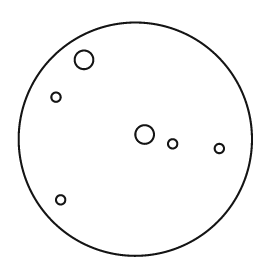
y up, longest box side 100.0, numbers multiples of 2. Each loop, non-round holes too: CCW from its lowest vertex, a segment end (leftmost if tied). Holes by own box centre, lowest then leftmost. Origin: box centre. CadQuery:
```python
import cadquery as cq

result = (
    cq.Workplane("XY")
    .moveTo(0.0, 0.0)
    .circle(50.0)
    .moveTo(-32.0, -26.0)
    .circle(2.0)
    .moveTo(36.0, -4.0)
    .circle(2.0)
    .moveTo(16.0, -2.0)
    .circle(2.0)
    .moveTo(4.0, 2.0)
    .circle(4.0)
    .moveTo(-34.0, 18.0)
    .circle(2.0)
    .moveTo(-22.0, 34.0)
    .circle(4.0)
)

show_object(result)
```